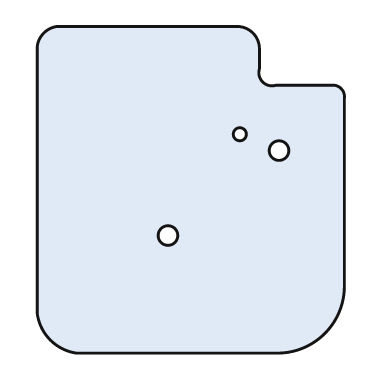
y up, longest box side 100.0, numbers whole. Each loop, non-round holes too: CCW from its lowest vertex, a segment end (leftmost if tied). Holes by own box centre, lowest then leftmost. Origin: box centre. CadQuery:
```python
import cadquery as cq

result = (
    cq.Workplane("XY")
    .moveTo(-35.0, -50.0)
    .lineTo(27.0, -50.0)
    .threePointArc((41.0, -44.0), (47.0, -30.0))
    .lineTo(47.0, 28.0)
    .threePointArc((46.0, 31.0), (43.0, 32.0))
    .lineTo(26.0, 32.0)
    .threePointArc((22.0, 33.0), (21.0, 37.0))
    .lineTo(21.0, 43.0)
    .threePointArc((19.0, 48.0), (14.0, 50.0))
    .lineTo(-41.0, 50.0)
    .threePointArc((-45.0, 48.0), (-47.0, 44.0))
    .lineTo(-47.0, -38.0)
    .threePointArc((-43.0, -46.0), (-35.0, -50.0))
    .close()
    .moveTo(-7.0, -14.0)
    .circle(3.0)
    .moveTo(27.0, 12.0)
    .circle(3.0)
    .moveTo(15.0, 17.0)
    .circle(2.0)
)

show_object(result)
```